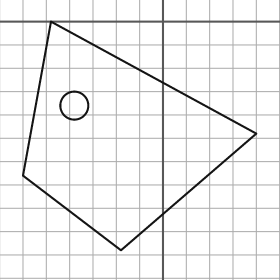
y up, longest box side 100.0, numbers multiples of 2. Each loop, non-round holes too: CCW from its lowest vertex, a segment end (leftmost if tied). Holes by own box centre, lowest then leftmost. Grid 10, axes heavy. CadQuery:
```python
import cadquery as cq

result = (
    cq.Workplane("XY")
    .moveTo(-18.0, -98.0)
    .lineTo(40.0, -48.0)
    .lineTo(-48.0, 0.0)
    .lineTo(-60.0, -66.0)
    .close()
    .moveTo(-38.0, -36.0)
    .circle(6.0)
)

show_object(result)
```